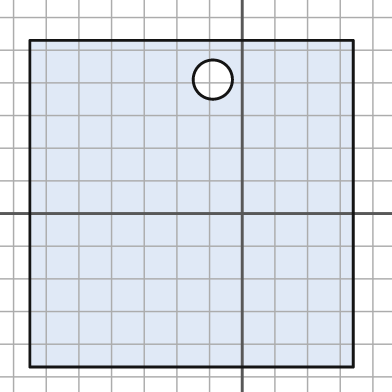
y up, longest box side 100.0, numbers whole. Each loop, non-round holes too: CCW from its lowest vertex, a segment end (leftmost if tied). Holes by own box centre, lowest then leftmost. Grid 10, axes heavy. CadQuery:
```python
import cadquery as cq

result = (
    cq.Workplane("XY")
    .moveTo(-65.0, -47.0)
    .lineTo(34.0, -47.0)
    .lineTo(34.0, 53.0)
    .lineTo(-65.0, 53.0)
    .close()
    .moveTo(-9.0, 41.0)
    .circle(6.0)
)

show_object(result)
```